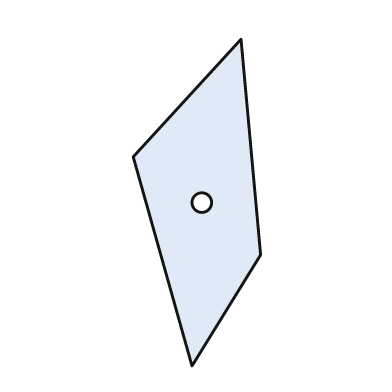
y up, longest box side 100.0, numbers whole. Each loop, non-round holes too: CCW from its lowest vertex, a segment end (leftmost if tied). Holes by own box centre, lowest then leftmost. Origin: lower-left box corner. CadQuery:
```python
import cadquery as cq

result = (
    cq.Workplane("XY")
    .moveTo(18.0, 0.0)
    .lineTo(39.0, 34.0)
    .lineTo(33.0, 100.0)
    .lineTo(0.0, 64.0)
    .close()
    .moveTo(21.0, 50.0)
    .circle(3.0)
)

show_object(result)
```